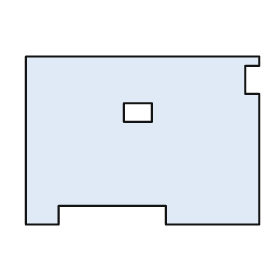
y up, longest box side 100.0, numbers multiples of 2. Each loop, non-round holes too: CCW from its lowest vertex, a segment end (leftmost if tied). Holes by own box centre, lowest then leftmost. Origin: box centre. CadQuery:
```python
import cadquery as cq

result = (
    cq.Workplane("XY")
    .moveTo(-50.0, -36.0)
    .lineTo(-36.0, -36.0)
    .lineTo(-36.0, -28.0)
    .lineTo(10.0, -28.0)
    .lineTo(10.0, -36.0)
    .lineTo(50.0, -36.0)
    .lineTo(50.0, 20.0)
    .lineTo(44.0, 20.0)
    .lineTo(44.0, 32.0)
    .lineTo(50.0, 32.0)
    .lineTo(50.0, 36.0)
    .lineTo(-50.0, 36.0)
    .close()
    .moveTo(-8.0, 8.0)
    .lineTo(4.0, 8.0)
    .lineTo(4.0, 16.0)
    .lineTo(-8.0, 16.0)
    .close()
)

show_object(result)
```